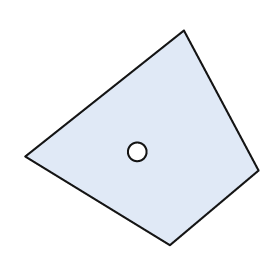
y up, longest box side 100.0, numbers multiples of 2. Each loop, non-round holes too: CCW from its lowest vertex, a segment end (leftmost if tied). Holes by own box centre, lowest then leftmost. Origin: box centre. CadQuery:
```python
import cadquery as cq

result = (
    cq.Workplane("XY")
    .moveTo(12.0, -46.0)
    .lineTo(50.0, -14.0)
    .lineTo(18.0, 46.0)
    .lineTo(-50.0, -8.0)
    .close()
    .moveTo(-2.0, -6.0)
    .circle(4.0)
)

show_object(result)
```